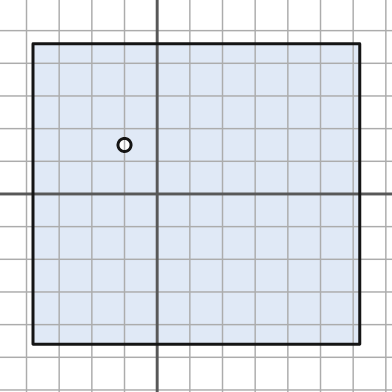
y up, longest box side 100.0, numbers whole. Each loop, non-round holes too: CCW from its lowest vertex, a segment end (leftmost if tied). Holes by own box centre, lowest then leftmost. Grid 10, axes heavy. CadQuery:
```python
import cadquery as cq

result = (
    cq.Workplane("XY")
    .moveTo(-38.0, -46.0)
    .lineTo(62.0, -46.0)
    .lineTo(62.0, 46.0)
    .lineTo(-38.0, 46.0)
    .close()
    .moveTo(-10.0, 15.0)
    .circle(2.0)
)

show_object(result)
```